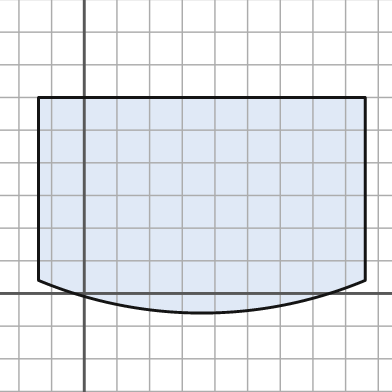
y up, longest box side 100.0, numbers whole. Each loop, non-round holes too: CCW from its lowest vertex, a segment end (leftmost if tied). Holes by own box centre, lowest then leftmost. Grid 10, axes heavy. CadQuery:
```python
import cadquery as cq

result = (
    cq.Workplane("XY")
    .moveTo(-14.0, 4.0)
    .threePointArc((36.0, -6.0), (86.0, 4.0))
    .lineTo(86.0, 60.0)
    .lineTo(-14.0, 60.0)
    .close()
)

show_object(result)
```